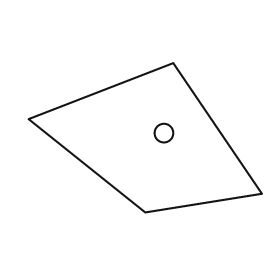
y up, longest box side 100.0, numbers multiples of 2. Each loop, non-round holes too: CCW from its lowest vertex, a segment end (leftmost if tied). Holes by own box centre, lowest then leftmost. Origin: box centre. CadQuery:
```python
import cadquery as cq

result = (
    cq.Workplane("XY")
    .moveTo(0.0, -32.0)
    .lineTo(50.0, -24.0)
    .lineTo(12.0, 32.0)
    .lineTo(-50.0, 8.0)
    .close()
    .moveTo(8.0, 2.0)
    .circle(4.0)
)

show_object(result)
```